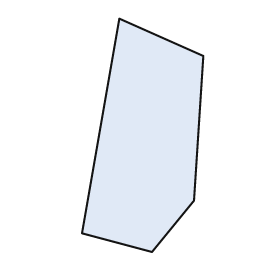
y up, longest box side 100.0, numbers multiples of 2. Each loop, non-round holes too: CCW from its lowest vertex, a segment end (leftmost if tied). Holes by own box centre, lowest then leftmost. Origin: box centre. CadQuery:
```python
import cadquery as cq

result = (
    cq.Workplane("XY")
    .moveTo(4.0, -50.0)
    .lineTo(22.0, -28.0)
    .lineTo(26.0, 34.0)
    .lineTo(-10.0, 50.0)
    .lineTo(-26.0, -42.0)
    .close()
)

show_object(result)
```